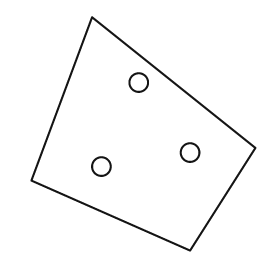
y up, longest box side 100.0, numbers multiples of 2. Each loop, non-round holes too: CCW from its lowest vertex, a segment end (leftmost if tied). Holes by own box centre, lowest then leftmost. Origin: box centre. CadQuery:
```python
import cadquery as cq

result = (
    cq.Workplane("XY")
    .moveTo(20.0, -50.0)
    .lineTo(48.0, -6.0)
    .lineTo(-22.0, 50.0)
    .lineTo(-48.0, -20.0)
    .close()
    .moveTo(-18.0, -14.0)
    .circle(4.0)
    .moveTo(20.0, -8.0)
    .circle(4.0)
    .moveTo(-2.0, 22.0)
    .circle(4.0)
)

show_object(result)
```